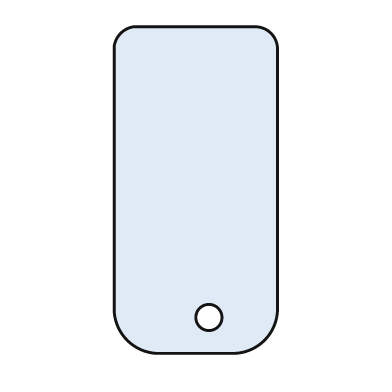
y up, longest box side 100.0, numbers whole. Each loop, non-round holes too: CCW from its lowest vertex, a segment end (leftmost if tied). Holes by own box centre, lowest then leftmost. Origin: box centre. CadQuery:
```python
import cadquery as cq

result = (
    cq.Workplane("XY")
    .moveTo(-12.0, -50.0)
    .lineTo(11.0, -50.0)
    .threePointArc((21.0, -46.0), (25.0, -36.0))
    .lineTo(25.0, 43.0)
    .threePointArc((23.0, 48.0), (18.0, 50.0))
    .lineTo(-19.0, 50.0)
    .threePointArc((-23.0, 48.0), (-25.0, 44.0))
    .lineTo(-25.0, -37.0)
    .threePointArc((-21.0, -46.0), (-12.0, -50.0))
    .close()
    .moveTo(4.0, -39.0)
    .circle(4.0)
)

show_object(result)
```